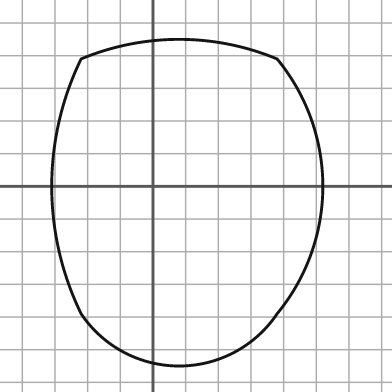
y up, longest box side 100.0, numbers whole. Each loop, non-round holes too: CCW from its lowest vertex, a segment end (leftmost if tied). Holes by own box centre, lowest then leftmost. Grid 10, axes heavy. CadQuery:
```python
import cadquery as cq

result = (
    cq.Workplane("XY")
    .moveTo(-22.0, -39.0)
    .threePointArc((8.0, -55.0), (38.0, -39.0))
    .threePointArc((52.0, 0.0), (38.0, 39.0))
    .threePointArc((8.0, 45.0), (-22.0, 39.0))
    .threePointArc((-31.0, 0.0), (-22.0, -39.0))
    .close()
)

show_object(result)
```